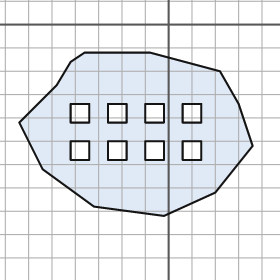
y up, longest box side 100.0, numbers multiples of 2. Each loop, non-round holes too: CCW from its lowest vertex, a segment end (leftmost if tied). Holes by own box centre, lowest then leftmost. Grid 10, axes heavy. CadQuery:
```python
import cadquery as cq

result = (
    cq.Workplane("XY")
    .moveTo(-2.0, -82.0)
    .lineTo(20.0, -72.0)
    .lineTo(36.0, -52.0)
    .lineTo(30.0, -34.0)
    .lineTo(22.0, -20.0)
    .lineTo(-8.0, -12.0)
    .lineTo(-36.0, -12.0)
    .lineTo(-42.0, -16.0)
    .lineTo(-48.0, -26.0)
    .lineTo(-64.0, -42.0)
    .lineTo(-54.0, -62.0)
    .lineTo(-32.0, -78.0)
    .close()
    .moveTo(-42.0, -58.0)
    .lineTo(-34.0, -58.0)
    .lineTo(-34.0, -50.0)
    .lineTo(-42.0, -50.0)
    .close()
    .moveTo(-26.0, -58.0)
    .lineTo(-18.0, -58.0)
    .lineTo(-18.0, -50.0)
    .lineTo(-26.0, -50.0)
    .close()
    .moveTo(-10.0, -58.0)
    .lineTo(-2.0, -58.0)
    .lineTo(-2.0, -50.0)
    .lineTo(-10.0, -50.0)
    .close()
    .moveTo(6.0, -58.0)
    .lineTo(14.0, -58.0)
    .lineTo(14.0, -50.0)
    .lineTo(6.0, -50.0)
    .close()
    .moveTo(-42.0, -42.0)
    .lineTo(-34.0, -42.0)
    .lineTo(-34.0, -34.0)
    .lineTo(-42.0, -34.0)
    .close()
    .moveTo(-26.0, -42.0)
    .lineTo(-18.0, -42.0)
    .lineTo(-18.0, -34.0)
    .lineTo(-26.0, -34.0)
    .close()
    .moveTo(-10.0, -42.0)
    .lineTo(-2.0, -42.0)
    .lineTo(-2.0, -34.0)
    .lineTo(-10.0, -34.0)
    .close()
    .moveTo(6.0, -42.0)
    .lineTo(14.0, -42.0)
    .lineTo(14.0, -34.0)
    .lineTo(6.0, -34.0)
    .close()
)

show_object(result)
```